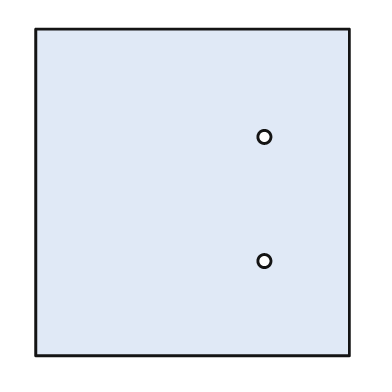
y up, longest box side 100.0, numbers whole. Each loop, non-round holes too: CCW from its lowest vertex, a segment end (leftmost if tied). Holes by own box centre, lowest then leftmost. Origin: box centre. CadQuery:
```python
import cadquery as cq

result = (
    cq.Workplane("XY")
    .moveTo(-48.0, -50.0)
    .lineTo(48.0, -50.0)
    .lineTo(48.0, 50.0)
    .lineTo(-48.0, 50.0)
    .close()
    .moveTo(22.0, -21.0)
    .circle(2.0)
    .moveTo(22.0, 17.0)
    .circle(2.0)
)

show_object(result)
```